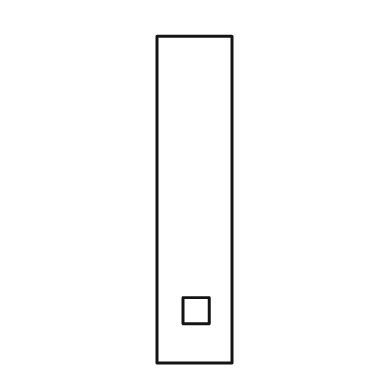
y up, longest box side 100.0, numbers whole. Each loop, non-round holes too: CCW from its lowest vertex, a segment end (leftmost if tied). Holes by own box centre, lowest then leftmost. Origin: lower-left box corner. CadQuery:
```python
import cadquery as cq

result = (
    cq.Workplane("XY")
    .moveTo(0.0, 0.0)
    .lineTo(23.0, 0.0)
    .lineTo(23.0, 100.0)
    .lineTo(0.0, 100.0)
    .close()
    .moveTo(8.0, 12.0)
    .lineTo(16.0, 12.0)
    .lineTo(16.0, 20.0)
    .lineTo(8.0, 20.0)
    .close()
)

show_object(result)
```